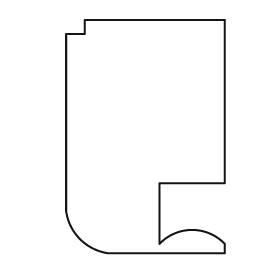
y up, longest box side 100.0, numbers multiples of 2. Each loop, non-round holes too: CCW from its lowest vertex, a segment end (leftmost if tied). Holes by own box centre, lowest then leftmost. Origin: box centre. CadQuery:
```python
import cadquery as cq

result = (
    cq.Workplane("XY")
    .moveTo(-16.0, -50.0)
    .lineTo(34.0, -50.0)
    .lineTo(34.0, -46.0)
    .threePointArc((20.0, -40.0), (6.0, -46.0))
    .lineTo(6.0, -20.0)
    .lineTo(34.0, -20.0)
    .lineTo(34.0, 50.0)
    .lineTo(-26.0, 50.0)
    .lineTo(-26.0, 44.0)
    .lineTo(-34.0, 44.0)
    .lineTo(-34.0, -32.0)
    .threePointArc((-28.0, -44.0), (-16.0, -50.0))
    .close()
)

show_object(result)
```